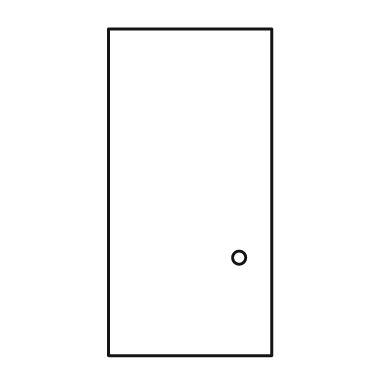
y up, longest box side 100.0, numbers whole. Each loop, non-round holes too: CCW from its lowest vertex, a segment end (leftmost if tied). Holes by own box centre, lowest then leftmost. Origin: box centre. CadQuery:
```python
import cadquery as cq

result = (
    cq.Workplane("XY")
    .moveTo(-25.0, -50.0)
    .lineTo(25.0, -50.0)
    .lineTo(25.0, 50.0)
    .lineTo(-25.0, 50.0)
    .close()
    .moveTo(15.0, -20.0)
    .circle(2.0)
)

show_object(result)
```